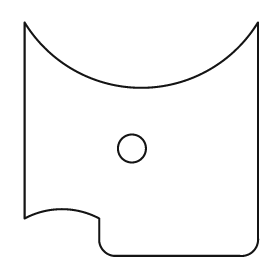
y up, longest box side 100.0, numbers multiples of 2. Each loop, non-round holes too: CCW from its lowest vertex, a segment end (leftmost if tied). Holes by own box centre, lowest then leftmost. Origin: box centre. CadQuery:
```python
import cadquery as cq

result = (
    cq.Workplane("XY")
    .moveTo(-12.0, -50.0)
    .lineTo(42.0, -50.0)
    .threePointArc((48.0, -48.0), (50.0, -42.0))
    .lineTo(50.0, 50.0)
    .threePointArc((0.0, 22.0), (-50.0, 50.0))
    .lineTo(-50.0, -34.0)
    .threePointArc((-34.0, -30.0), (-18.0, -34.0))
    .lineTo(-18.0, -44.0)
    .threePointArc((-16.0, -48.0), (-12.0, -50.0))
    .close()
    .moveTo(-4.0, -4.0)
    .circle(6.0)
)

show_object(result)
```